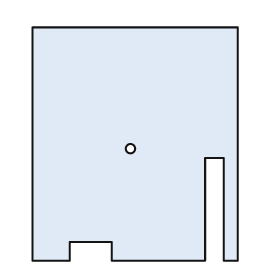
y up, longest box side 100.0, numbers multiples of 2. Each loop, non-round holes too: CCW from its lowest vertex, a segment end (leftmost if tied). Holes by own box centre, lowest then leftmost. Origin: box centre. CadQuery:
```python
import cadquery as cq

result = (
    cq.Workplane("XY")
    .moveTo(-44.0, -50.0)
    .lineTo(-28.0, -50.0)
    .lineTo(-28.0, -42.0)
    .lineTo(-10.0, -42.0)
    .lineTo(-10.0, -50.0)
    .lineTo(30.0, -50.0)
    .lineTo(30.0, -6.0)
    .lineTo(38.0, -6.0)
    .lineTo(38.0, -50.0)
    .lineTo(44.0, -50.0)
    .lineTo(44.0, 50.0)
    .lineTo(-44.0, 50.0)
    .close()
    .moveTo(-2.0, -2.0)
    .circle(2.0)
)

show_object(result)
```